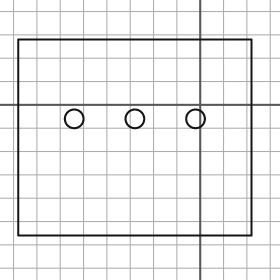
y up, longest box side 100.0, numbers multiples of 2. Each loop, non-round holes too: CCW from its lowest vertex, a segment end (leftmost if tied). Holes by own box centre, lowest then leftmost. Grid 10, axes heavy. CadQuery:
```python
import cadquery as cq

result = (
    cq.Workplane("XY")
    .moveTo(-78.0, -56.0)
    .lineTo(22.0, -56.0)
    .lineTo(22.0, 28.0)
    .lineTo(-78.0, 28.0)
    .close()
    .moveTo(-54.0, -6.0)
    .circle(4.0)
    .moveTo(-28.0, -6.0)
    .circle(4.0)
    .moveTo(-2.0, -6.0)
    .circle(4.0)
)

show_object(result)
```